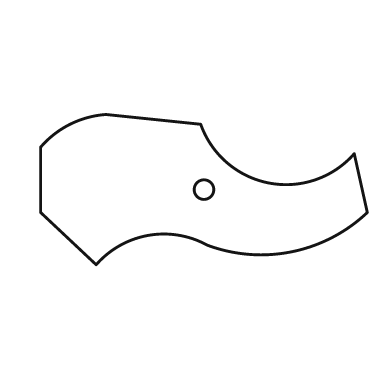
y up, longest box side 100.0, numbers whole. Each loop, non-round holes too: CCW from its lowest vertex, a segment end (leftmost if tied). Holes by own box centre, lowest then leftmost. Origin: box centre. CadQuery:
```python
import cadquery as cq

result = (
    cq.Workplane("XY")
    .moveTo(-33.0, -23.0)
    .threePointArc((-17.0, -14.0), (1.0, -17.0))
    .threePointArc((27.0, -19.0), (50.0, -7.0))
    .lineTo(46.0, 11.0)
    .threePointArc((20.0, 2.0), (-1.0, 20.0))
    .lineTo(-30.0, 23.0)
    .threePointArc((-41.0, 20.0), (-50.0, 13.0))
    .lineTo(-50.0, -7.0)
    .close()
    .moveTo(0.0, 0.0)
    .circle(3.0)
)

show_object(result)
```